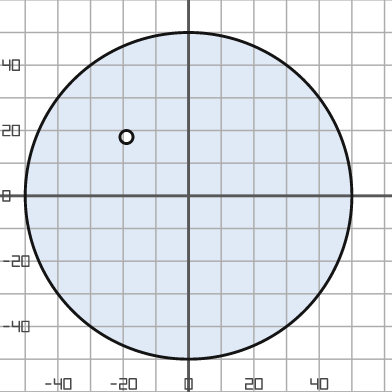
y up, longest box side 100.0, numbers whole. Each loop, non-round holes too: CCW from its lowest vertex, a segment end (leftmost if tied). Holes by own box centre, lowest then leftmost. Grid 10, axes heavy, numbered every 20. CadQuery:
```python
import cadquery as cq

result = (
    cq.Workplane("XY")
    .moveTo(0.0, 0.0)
    .circle(50.0)
    .moveTo(-19.0, 18.0)
    .circle(2.0)
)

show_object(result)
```